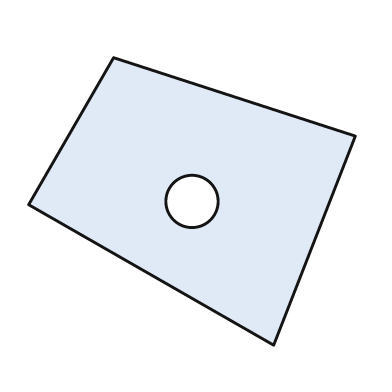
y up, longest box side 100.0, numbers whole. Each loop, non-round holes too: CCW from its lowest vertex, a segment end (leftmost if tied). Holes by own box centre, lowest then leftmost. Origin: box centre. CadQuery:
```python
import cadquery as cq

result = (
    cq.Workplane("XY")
    .moveTo(25.0, -44.0)
    .lineTo(50.0, 20.0)
    .lineTo(-24.0, 44.0)
    .lineTo(-50.0, -1.0)
    .close()
    .moveTo(0.0, 0.0)
    .circle(8.0)
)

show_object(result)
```